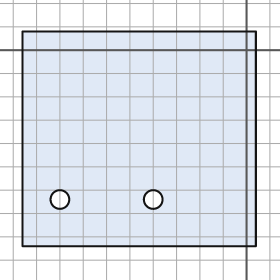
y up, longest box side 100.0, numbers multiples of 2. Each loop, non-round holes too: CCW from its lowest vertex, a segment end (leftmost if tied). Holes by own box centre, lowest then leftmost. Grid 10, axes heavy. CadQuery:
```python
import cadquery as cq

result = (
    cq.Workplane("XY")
    .moveTo(-96.0, -84.0)
    .lineTo(4.0, -84.0)
    .lineTo(4.0, 8.0)
    .lineTo(-96.0, 8.0)
    .close()
    .moveTo(-80.0, -64.0)
    .circle(4.0)
    .moveTo(-40.0, -64.0)
    .circle(4.0)
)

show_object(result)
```